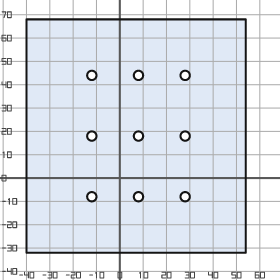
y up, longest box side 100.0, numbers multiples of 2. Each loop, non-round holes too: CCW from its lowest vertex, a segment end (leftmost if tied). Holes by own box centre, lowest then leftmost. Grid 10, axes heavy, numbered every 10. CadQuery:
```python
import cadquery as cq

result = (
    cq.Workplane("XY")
    .moveTo(-40.0, -32.0)
    .lineTo(54.0, -32.0)
    .lineTo(54.0, 68.0)
    .lineTo(-40.0, 68.0)
    .close()
    .moveTo(-12.0, -8.0)
    .circle(2.0)
    .moveTo(8.0, -8.0)
    .circle(2.0)
    .moveTo(28.0, -8.0)
    .circle(2.0)
    .moveTo(-12.0, 18.0)
    .circle(2.0)
    .moveTo(8.0, 18.0)
    .circle(2.0)
    .moveTo(28.0, 18.0)
    .circle(2.0)
    .moveTo(-12.0, 44.0)
    .circle(2.0)
    .moveTo(8.0, 44.0)
    .circle(2.0)
    .moveTo(28.0, 44.0)
    .circle(2.0)
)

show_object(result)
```